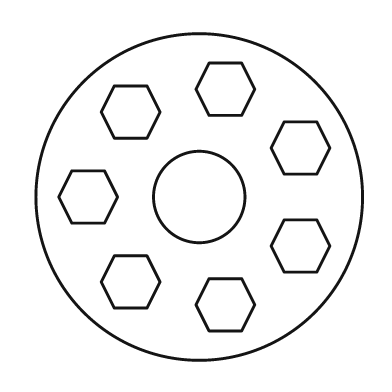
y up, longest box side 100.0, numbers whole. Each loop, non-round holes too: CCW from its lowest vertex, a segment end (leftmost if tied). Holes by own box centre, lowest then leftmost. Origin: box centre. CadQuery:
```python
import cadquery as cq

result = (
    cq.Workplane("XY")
    .moveTo(0.0, 0.0)
    .circle(50.0)
    .moveTo(3.0, -41.0)
    .lineTo(13.0, -41.0)
    .lineTo(17.0, -33.0)
    .lineTo(13.0, -25.0)
    .lineTo(3.0, -25.0)
    .lineTo(-1.0, -33.0)
    .close()
    .moveTo(-26.0, -34.0)
    .lineTo(-16.0, -34.0)
    .lineTo(-12.0, -26.0)
    .lineTo(-16.0, -18.0)
    .lineTo(-26.0, -18.0)
    .lineTo(-30.0, -26.0)
    .close()
    .moveTo(26.0, -23.0)
    .lineTo(36.0, -23.0)
    .lineTo(40.0, -15.0)
    .lineTo(36.0, -7.0)
    .lineTo(26.0, -7.0)
    .lineTo(22.0, -15.0)
    .close()
    .moveTo(-39.0, -8.0)
    .lineTo(-29.0, -8.0)
    .lineTo(-25.0, 0.0)
    .lineTo(-29.0, 8.0)
    .lineTo(-39.0, 8.0)
    .lineTo(-43.0, 0.0)
    .close()
    .moveTo(0.0, 0.0)
    .circle(14.0)
    .moveTo(26.0, 7.0)
    .lineTo(36.0, 7.0)
    .lineTo(40.0, 15.0)
    .lineTo(36.0, 23.0)
    .lineTo(26.0, 23.0)
    .lineTo(22.0, 15.0)
    .close()
    .moveTo(-26.0, 18.0)
    .lineTo(-16.0, 18.0)
    .lineTo(-12.0, 26.0)
    .lineTo(-16.0, 34.0)
    .lineTo(-26.0, 34.0)
    .lineTo(-30.0, 26.0)
    .close()
    .moveTo(3.0, 25.0)
    .lineTo(13.0, 25.0)
    .lineTo(17.0, 33.0)
    .lineTo(13.0, 41.0)
    .lineTo(3.0, 41.0)
    .lineTo(-1.0, 33.0)
    .close()
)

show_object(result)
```